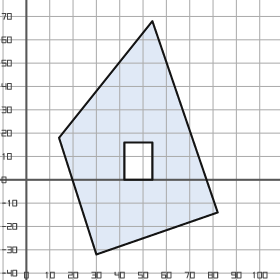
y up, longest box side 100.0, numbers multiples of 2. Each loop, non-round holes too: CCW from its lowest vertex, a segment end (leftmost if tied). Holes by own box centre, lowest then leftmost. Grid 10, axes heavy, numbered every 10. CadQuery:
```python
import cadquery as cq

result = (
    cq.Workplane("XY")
    .moveTo(30.0, -32.0)
    .lineTo(82.0, -14.0)
    .lineTo(54.0, 68.0)
    .lineTo(14.0, 18.0)
    .close()
    .moveTo(42.0, 0.0)
    .lineTo(54.0, 0.0)
    .lineTo(54.0, 16.0)
    .lineTo(42.0, 16.0)
    .close()
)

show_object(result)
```